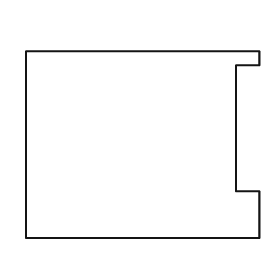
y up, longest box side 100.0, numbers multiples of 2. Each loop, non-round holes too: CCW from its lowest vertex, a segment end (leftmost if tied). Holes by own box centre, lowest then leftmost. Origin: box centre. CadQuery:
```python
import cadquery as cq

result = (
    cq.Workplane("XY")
    .moveTo(-50.0, -40.0)
    .lineTo(50.0, -40.0)
    .lineTo(50.0, -20.0)
    .lineTo(40.0, -20.0)
    .lineTo(40.0, 34.0)
    .lineTo(50.0, 34.0)
    .lineTo(50.0, 40.0)
    .lineTo(-50.0, 40.0)
    .close()
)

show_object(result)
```